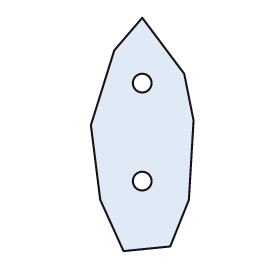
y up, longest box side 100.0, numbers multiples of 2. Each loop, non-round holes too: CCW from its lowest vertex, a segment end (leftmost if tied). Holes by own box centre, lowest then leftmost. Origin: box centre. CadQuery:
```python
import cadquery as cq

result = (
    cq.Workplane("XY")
    .moveTo(-8.0, -50.0)
    .lineTo(12.0, -48.0)
    .lineTo(20.0, -28.0)
    .lineTo(22.0, 6.0)
    .lineTo(18.0, 26.0)
    .lineTo(0.0, 50.0)
    .lineTo(-12.0, 36.0)
    .lineTo(-22.0, 4.0)
    .lineTo(-18.0, -28.0)
    .close()
    .moveTo(0.0, -20.0)
    .circle(4.0)
    .moveTo(0.0, 22.0)
    .circle(4.0)
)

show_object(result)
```